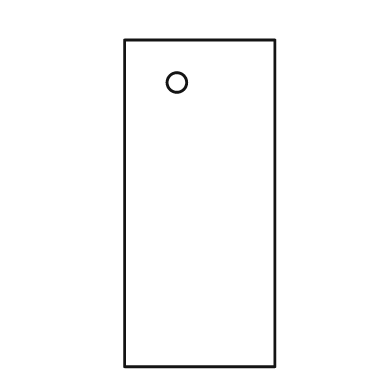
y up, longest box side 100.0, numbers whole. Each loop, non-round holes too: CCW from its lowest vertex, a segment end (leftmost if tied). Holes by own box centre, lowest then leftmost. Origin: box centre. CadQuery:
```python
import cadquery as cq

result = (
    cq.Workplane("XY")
    .moveTo(-23.0, -50.0)
    .lineTo(23.0, -50.0)
    .lineTo(23.0, 50.0)
    .lineTo(-23.0, 50.0)
    .close()
    .moveTo(-7.0, 37.0)
    .circle(3.0)
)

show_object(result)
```